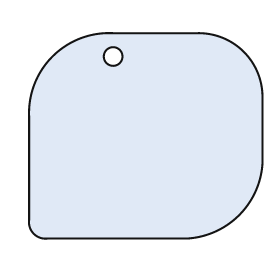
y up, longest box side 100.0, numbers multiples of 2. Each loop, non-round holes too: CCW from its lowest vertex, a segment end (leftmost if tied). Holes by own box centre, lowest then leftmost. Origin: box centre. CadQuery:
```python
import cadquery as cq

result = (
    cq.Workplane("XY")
    .moveTo(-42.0, -44.0)
    .lineTo(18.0, -44.0)
    .threePointArc((40.0, -34.0), (50.0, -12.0))
    .lineTo(50.0, 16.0)
    .threePointArc((42.0, 36.0), (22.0, 44.0))
    .lineTo(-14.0, 44.0)
    .threePointArc((-40.0, 34.0), (-50.0, 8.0))
    .lineTo(-50.0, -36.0)
    .threePointArc((-48.0, -42.0), (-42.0, -44.0))
    .close()
    .moveTo(-14.0, 34.0)
    .circle(4.0)
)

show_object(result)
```